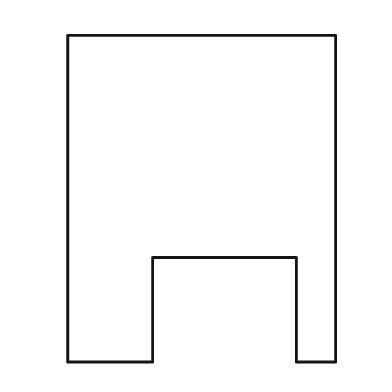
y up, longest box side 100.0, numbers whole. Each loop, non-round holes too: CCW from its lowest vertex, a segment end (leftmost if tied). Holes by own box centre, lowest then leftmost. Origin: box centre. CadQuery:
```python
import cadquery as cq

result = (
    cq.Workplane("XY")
    .moveTo(-41.0, -50.0)
    .lineTo(-15.0, -50.0)
    .lineTo(-15.0, -18.0)
    .lineTo(29.0, -18.0)
    .lineTo(29.0, -50.0)
    .lineTo(41.0, -50.0)
    .lineTo(41.0, 50.0)
    .lineTo(-41.0, 50.0)
    .close()
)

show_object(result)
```